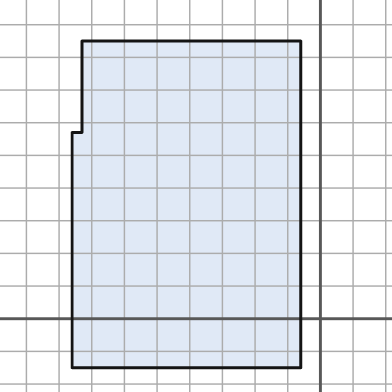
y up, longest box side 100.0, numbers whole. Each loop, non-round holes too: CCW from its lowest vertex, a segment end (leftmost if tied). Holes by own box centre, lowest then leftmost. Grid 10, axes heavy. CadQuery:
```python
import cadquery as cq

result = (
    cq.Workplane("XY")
    .moveTo(-76.0, -15.0)
    .lineTo(-6.0, -15.0)
    .lineTo(-6.0, 85.0)
    .lineTo(-73.0, 85.0)
    .lineTo(-73.0, 57.0)
    .lineTo(-76.0, 57.0)
    .close()
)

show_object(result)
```